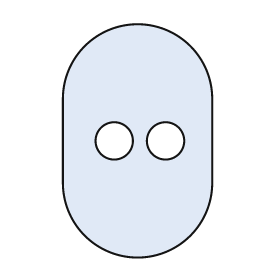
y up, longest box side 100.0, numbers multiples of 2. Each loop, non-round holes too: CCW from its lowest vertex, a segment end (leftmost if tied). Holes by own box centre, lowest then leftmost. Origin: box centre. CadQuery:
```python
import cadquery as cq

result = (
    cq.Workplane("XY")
    .moveTo(-32.0, -18.0)
    .threePointArc((0.0, -50.0), (32.0, -18.0))
    .lineTo(32.0, 18.0)
    .threePointArc((0.0, 50.0), (-32.0, 18.0))
    .close()
    .moveTo(-10.0, 0.0)
    .circle(8.0)
    .moveTo(12.0, 0.0)
    .circle(8.0)
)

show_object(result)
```